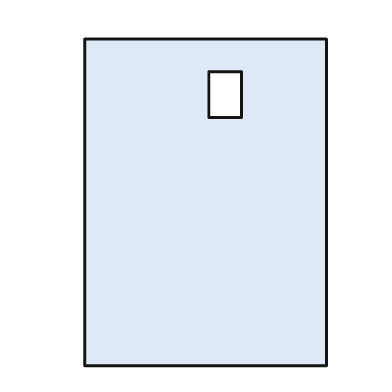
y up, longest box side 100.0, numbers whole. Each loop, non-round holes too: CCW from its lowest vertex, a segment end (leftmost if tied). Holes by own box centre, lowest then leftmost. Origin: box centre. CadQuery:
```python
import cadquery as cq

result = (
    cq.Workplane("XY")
    .moveTo(-37.0, -50.0)
    .lineTo(37.0, -50.0)
    .lineTo(37.0, 50.0)
    .lineTo(-37.0, 50.0)
    .close()
    .moveTo(1.0, 26.0)
    .lineTo(11.0, 26.0)
    .lineTo(11.0, 40.0)
    .lineTo(1.0, 40.0)
    .close()
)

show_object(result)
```